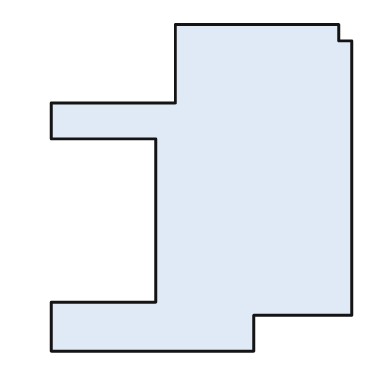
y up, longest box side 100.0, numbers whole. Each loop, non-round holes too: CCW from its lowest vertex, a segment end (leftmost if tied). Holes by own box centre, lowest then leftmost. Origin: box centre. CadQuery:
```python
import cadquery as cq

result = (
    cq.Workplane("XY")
    .moveTo(-46.0, -50.0)
    .lineTo(16.0, -50.0)
    .lineTo(16.0, -39.0)
    .lineTo(46.0, -39.0)
    .lineTo(46.0, 45.0)
    .lineTo(42.0, 45.0)
    .lineTo(42.0, 50.0)
    .lineTo(-8.0, 50.0)
    .lineTo(-8.0, 26.0)
    .lineTo(-46.0, 26.0)
    .lineTo(-46.0, 15.0)
    .lineTo(-14.0, 15.0)
    .lineTo(-14.0, -35.0)
    .lineTo(-46.0, -35.0)
    .close()
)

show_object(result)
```